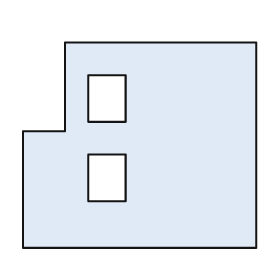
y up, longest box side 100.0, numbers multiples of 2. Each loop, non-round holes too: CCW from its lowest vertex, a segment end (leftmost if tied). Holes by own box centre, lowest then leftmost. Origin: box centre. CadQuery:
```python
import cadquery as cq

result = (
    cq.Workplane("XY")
    .moveTo(-50.0, -44.0)
    .lineTo(50.0, -44.0)
    .lineTo(50.0, 44.0)
    .lineTo(-32.0, 44.0)
    .lineTo(-32.0, 6.0)
    .lineTo(-50.0, 6.0)
    .close()
    .moveTo(-22.0, -24.0)
    .lineTo(-6.0, -24.0)
    .lineTo(-6.0, -4.0)
    .lineTo(-22.0, -4.0)
    .close()
    .moveTo(-22.0, 10.0)
    .lineTo(-6.0, 10.0)
    .lineTo(-6.0, 30.0)
    .lineTo(-22.0, 30.0)
    .close()
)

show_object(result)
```